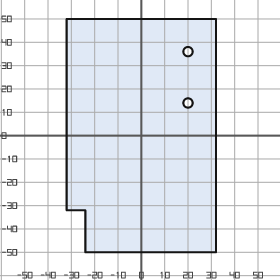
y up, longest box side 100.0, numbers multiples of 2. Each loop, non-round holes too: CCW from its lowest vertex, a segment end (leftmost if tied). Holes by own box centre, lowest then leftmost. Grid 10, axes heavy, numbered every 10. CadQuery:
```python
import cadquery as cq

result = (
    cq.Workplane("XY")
    .moveTo(-24.0, -50.0)
    .lineTo(32.0, -50.0)
    .lineTo(32.0, 50.0)
    .lineTo(-32.0, 50.0)
    .lineTo(-32.0, -32.0)
    .lineTo(-24.0, -32.0)
    .close()
    .moveTo(20.0, 14.0)
    .circle(2.0)
    .moveTo(20.0, 36.0)
    .circle(2.0)
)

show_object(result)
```